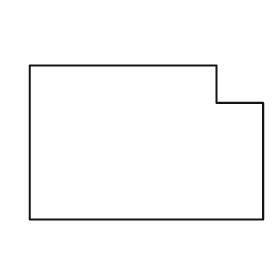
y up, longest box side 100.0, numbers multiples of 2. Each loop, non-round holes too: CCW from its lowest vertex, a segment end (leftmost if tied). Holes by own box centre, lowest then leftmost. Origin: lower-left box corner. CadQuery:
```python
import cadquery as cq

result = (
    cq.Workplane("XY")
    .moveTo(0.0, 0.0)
    .lineTo(100.0, 0.0)
    .lineTo(100.0, 50.0)
    .lineTo(80.0, 50.0)
    .lineTo(80.0, 66.0)
    .lineTo(0.0, 66.0)
    .close()
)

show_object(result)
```